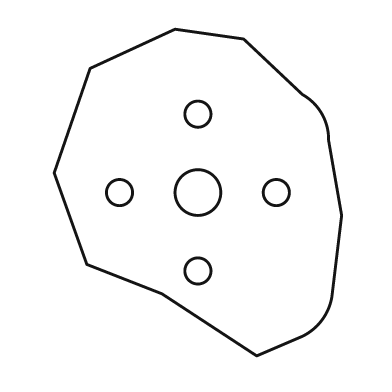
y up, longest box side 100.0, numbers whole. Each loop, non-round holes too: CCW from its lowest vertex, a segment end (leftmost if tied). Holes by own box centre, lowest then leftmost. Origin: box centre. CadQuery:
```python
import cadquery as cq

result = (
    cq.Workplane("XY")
    .moveTo(18.0, -50.0)
    .lineTo(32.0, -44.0)
    .threePointArc((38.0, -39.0), (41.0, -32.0))
    .lineTo(44.0, -7.0)
    .lineTo(40.0, 16.0)
    .threePointArc((38.0, 24.0), (32.0, 30.0))
    .lineTo(14.0, 47.0)
    .lineTo(-7.0, 50.0)
    .lineTo(-33.0, 38.0)
    .lineTo(-44.0, 6.0)
    .lineTo(-34.0, -22.0)
    .lineTo(-11.0, -31.0)
    .close()
    .moveTo(0.0, -24.0)
    .circle(4.0)
    .moveTo(-24.0, 0.0)
    .circle(4.0)
    .moveTo(0.0, 0.0)
    .circle(7.0)
    .moveTo(24.0, 0.0)
    .circle(4.0)
    .moveTo(0.0, 24.0)
    .circle(4.0)
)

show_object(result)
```